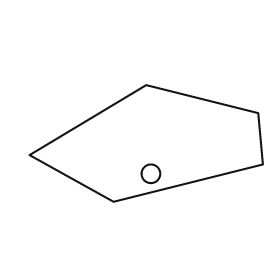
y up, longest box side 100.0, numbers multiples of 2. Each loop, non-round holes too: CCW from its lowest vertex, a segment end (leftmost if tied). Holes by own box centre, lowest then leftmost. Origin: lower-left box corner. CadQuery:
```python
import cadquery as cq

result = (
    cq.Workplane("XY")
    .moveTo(36.0, 0.0)
    .lineTo(100.0, 16.0)
    .lineTo(98.0, 38.0)
    .lineTo(50.0, 50.0)
    .lineTo(0.0, 20.0)
    .close()
    .moveTo(52.0, 12.0)
    .circle(4.0)
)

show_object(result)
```